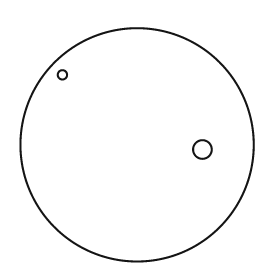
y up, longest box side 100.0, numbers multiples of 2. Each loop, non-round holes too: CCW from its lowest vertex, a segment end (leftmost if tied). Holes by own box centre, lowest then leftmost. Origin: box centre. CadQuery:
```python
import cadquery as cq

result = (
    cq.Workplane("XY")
    .moveTo(0.0, 0.0)
    .circle(50.0)
    .moveTo(28.0, -2.0)
    .circle(4.0)
    .moveTo(-32.0, 30.0)
    .circle(2.0)
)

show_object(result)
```